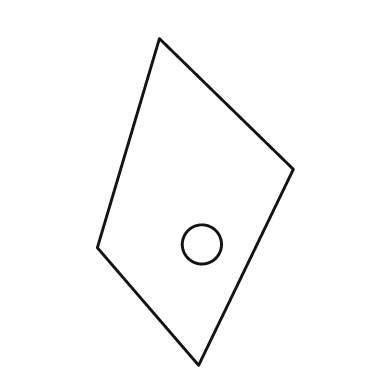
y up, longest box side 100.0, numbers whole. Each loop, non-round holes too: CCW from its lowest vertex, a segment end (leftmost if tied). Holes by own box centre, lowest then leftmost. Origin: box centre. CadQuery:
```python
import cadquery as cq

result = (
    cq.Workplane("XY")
    .moveTo(1.0, -50.0)
    .lineTo(30.0, 10.0)
    .lineTo(-11.0, 50.0)
    .lineTo(-30.0, -14.0)
    .close()
    .moveTo(2.0, -13.0)
    .circle(6.0)
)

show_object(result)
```